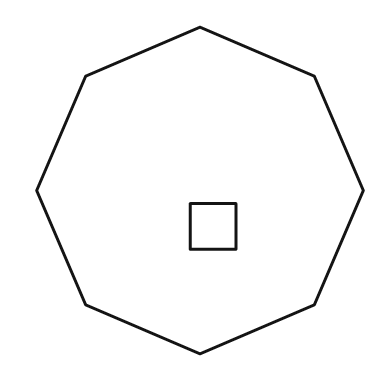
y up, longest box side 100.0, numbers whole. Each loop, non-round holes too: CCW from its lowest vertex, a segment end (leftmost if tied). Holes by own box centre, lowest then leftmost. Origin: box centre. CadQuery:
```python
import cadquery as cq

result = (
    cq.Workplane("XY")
    .moveTo(0.0, -50.0)
    .lineTo(35.0, -35.0)
    .lineTo(50.0, 0.0)
    .lineTo(35.0, 35.0)
    .lineTo(0.0, 50.0)
    .lineTo(-35.0, 35.0)
    .lineTo(-50.0, 0.0)
    .lineTo(-35.0, -35.0)
    .close()
    .moveTo(-3.0, -18.0)
    .lineTo(11.0, -18.0)
    .lineTo(11.0, -4.0)
    .lineTo(-3.0, -4.0)
    .close()
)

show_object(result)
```